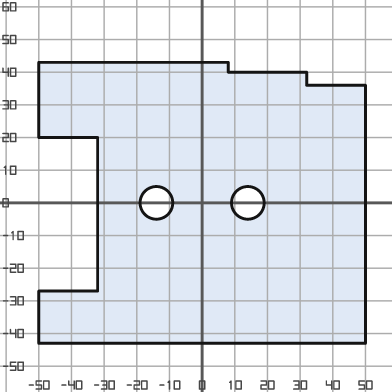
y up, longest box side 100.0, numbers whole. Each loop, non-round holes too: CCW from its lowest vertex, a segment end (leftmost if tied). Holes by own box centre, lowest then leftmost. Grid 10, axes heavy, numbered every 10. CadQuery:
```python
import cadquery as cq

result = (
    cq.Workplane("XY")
    .moveTo(-50.0, -43.0)
    .lineTo(50.0, -43.0)
    .lineTo(50.0, 36.0)
    .lineTo(32.0, 36.0)
    .lineTo(32.0, 40.0)
    .lineTo(8.0, 40.0)
    .lineTo(8.0, 43.0)
    .lineTo(-50.0, 43.0)
    .lineTo(-50.0, 20.0)
    .lineTo(-32.0, 20.0)
    .lineTo(-32.0, -27.0)
    .lineTo(-50.0, -27.0)
    .close()
    .moveTo(-14.0, 0.0)
    .circle(5.0)
    .moveTo(14.0, 0.0)
    .circle(5.0)
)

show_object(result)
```